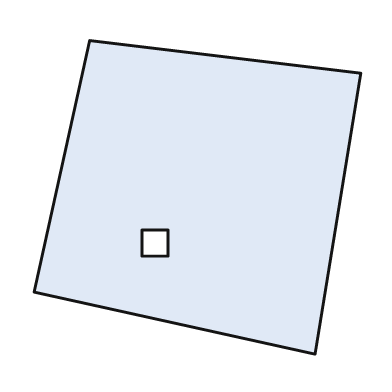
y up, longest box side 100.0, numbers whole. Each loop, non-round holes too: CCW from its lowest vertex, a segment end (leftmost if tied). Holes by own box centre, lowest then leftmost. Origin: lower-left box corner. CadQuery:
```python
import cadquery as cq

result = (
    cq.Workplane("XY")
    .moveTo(86.0, 0.0)
    .lineTo(100.0, 86.0)
    .lineTo(17.0, 96.0)
    .lineTo(0.0, 19.0)
    .close()
    .moveTo(33.0, 30.0)
    .lineTo(41.0, 30.0)
    .lineTo(41.0, 38.0)
    .lineTo(33.0, 38.0)
    .close()
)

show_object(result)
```